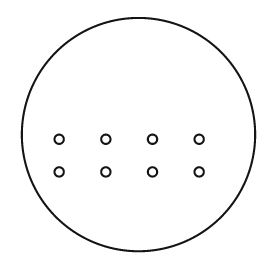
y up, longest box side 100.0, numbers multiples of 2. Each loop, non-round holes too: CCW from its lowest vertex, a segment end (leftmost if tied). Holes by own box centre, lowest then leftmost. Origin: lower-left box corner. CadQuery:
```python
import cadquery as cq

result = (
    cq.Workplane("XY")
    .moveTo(50.0, 50.0)
    .circle(50.0)
    .moveTo(16.0, 34.0)
    .circle(2.0)
    .moveTo(36.0, 34.0)
    .circle(2.0)
    .moveTo(56.0, 34.0)
    .circle(2.0)
    .moveTo(76.0, 34.0)
    .circle(2.0)
    .moveTo(16.0, 48.0)
    .circle(2.0)
    .moveTo(36.0, 48.0)
    .circle(2.0)
    .moveTo(56.0, 48.0)
    .circle(2.0)
    .moveTo(76.0, 48.0)
    .circle(2.0)
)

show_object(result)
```